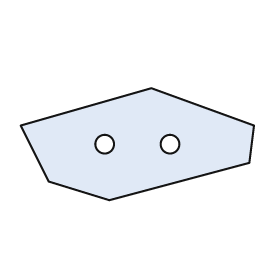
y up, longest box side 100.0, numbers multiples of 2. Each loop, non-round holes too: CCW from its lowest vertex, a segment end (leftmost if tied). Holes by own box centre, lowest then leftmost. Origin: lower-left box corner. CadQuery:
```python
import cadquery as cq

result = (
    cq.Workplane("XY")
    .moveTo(38.0, 0.0)
    .lineTo(98.0, 16.0)
    .lineTo(100.0, 32.0)
    .lineTo(56.0, 48.0)
    .lineTo(0.0, 32.0)
    .lineTo(12.0, 8.0)
    .close()
    .moveTo(36.0, 24.0)
    .circle(4.0)
    .moveTo(64.0, 24.0)
    .circle(4.0)
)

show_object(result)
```